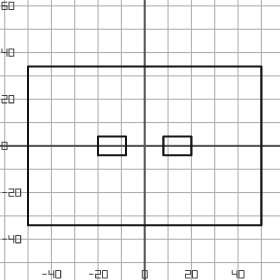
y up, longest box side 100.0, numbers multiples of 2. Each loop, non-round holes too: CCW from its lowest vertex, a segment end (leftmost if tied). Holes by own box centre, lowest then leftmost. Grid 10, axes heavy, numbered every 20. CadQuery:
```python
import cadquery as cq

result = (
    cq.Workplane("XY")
    .moveTo(-50.0, -34.0)
    .lineTo(50.0, -34.0)
    .lineTo(50.0, 34.0)
    .lineTo(-50.0, 34.0)
    .close()
    .moveTo(-20.0, -4.0)
    .lineTo(-8.0, -4.0)
    .lineTo(-8.0, 4.0)
    .lineTo(-20.0, 4.0)
    .close()
    .moveTo(8.0, -4.0)
    .lineTo(20.0, -4.0)
    .lineTo(20.0, 4.0)
    .lineTo(8.0, 4.0)
    .close()
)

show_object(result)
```